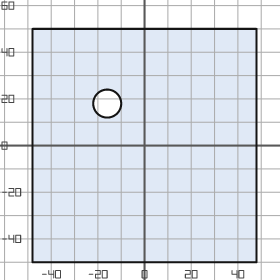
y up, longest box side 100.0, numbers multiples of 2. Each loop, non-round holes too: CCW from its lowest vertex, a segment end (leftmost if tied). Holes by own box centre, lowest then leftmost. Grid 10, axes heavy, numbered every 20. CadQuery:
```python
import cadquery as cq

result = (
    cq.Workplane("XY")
    .moveTo(-48.0, -50.0)
    .lineTo(48.0, -50.0)
    .lineTo(48.0, 50.0)
    .lineTo(-48.0, 50.0)
    .close()
    .moveTo(-16.0, 18.0)
    .circle(6.0)
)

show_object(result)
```